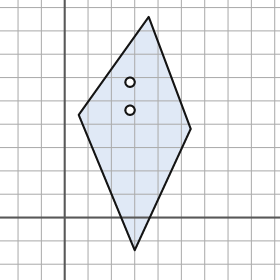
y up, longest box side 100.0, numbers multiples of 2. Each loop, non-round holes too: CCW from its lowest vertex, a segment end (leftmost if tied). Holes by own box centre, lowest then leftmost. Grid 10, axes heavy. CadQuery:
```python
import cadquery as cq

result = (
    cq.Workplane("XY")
    .moveTo(30.0, -14.0)
    .lineTo(54.0, 38.0)
    .lineTo(36.0, 86.0)
    .lineTo(6.0, 44.0)
    .close()
    .moveTo(28.0, 46.0)
    .circle(2.0)
    .moveTo(28.0, 58.0)
    .circle(2.0)
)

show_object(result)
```